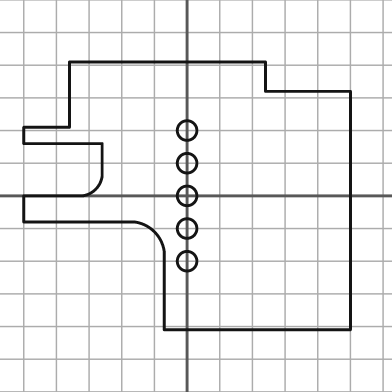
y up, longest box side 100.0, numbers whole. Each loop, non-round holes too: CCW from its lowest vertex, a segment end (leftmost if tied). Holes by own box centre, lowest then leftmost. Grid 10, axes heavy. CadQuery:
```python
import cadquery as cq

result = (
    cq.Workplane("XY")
    .moveTo(-7.0, -41.0)
    .lineTo(50.0, -41.0)
    .lineTo(50.0, 32.0)
    .lineTo(24.0, 32.0)
    .lineTo(24.0, 41.0)
    .lineTo(-36.0, 41.0)
    .lineTo(-36.0, 21.0)
    .lineTo(-50.0, 21.0)
    .lineTo(-50.0, 16.0)
    .lineTo(-26.0, 16.0)
    .lineTo(-26.0, 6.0)
    .threePointArc((-28.0, 2.0), (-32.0, 0.0))
    .lineTo(-50.0, 0.0)
    .lineTo(-50.0, -8.0)
    .lineTo(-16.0, -8.0)
    .threePointArc((-10.0, -11.0), (-7.0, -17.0))
    .close()
    .moveTo(0.0, -20.0)
    .circle(3.0)
    .moveTo(0.0, -10.0)
    .circle(3.0)
    .moveTo(0.0, 0.0)
    .circle(3.0)
    .moveTo(0.0, 10.0)
    .circle(3.0)
    .moveTo(0.0, 20.0)
    .circle(3.0)
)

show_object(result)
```